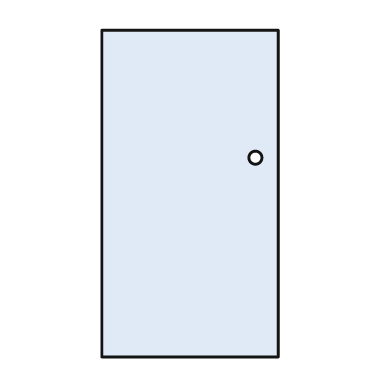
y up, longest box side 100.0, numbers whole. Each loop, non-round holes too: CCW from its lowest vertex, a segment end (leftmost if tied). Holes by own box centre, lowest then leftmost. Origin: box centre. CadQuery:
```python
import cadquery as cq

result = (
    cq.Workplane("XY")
    .moveTo(-27.0, -50.0)
    .lineTo(27.0, -50.0)
    .lineTo(27.0, 50.0)
    .lineTo(-27.0, 50.0)
    .close()
    .moveTo(20.0, 11.0)
    .circle(2.0)
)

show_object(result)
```